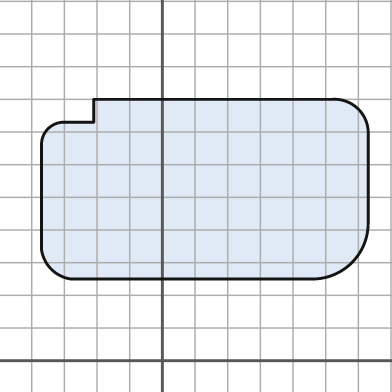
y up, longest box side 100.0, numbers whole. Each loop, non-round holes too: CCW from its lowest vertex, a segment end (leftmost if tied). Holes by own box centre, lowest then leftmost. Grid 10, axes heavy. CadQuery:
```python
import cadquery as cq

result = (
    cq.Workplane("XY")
    .moveTo(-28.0, 25.0)
    .lineTo(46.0, 25.0)
    .threePointArc((58.0, 30.0), (63.0, 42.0))
    .lineTo(63.0, 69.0)
    .threePointArc((60.0, 77.0), (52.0, 80.0))
    .lineTo(-21.0, 80.0)
    .lineTo(-21.0, 73.0)
    .lineTo(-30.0, 73.0)
    .threePointArc((-35.0, 71.0), (-37.0, 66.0))
    .lineTo(-37.0, 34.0)
    .threePointArc((-34.0, 28.0), (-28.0, 25.0))
    .close()
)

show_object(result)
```